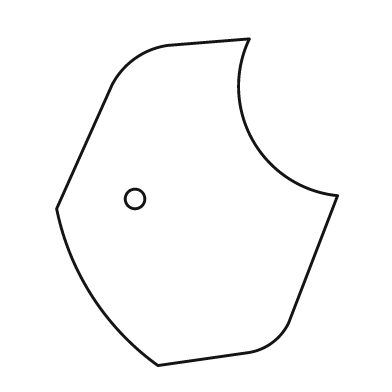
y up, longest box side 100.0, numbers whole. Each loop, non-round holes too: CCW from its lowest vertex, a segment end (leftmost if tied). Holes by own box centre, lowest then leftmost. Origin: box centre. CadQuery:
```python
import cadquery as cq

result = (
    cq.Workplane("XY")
    .moveTo(-12.0, -50.0)
    .lineTo(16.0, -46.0)
    .threePointArc((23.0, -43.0), (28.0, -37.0))
    .lineTo(43.0, 2.0)
    .threePointArc((17.0, 19.0), (16.0, 50.0))
    .lineTo(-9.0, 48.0)
    .threePointArc((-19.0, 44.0), (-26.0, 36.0))
    .lineTo(-43.0, -2.0)
    .threePointArc((-32.0, -29.0), (-12.0, -50.0))
    .close()
    .moveTo(-19.0, 1.0)
    .circle(3.0)
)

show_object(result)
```